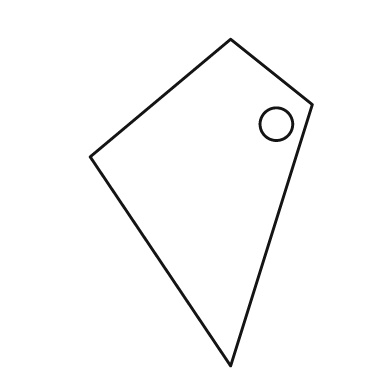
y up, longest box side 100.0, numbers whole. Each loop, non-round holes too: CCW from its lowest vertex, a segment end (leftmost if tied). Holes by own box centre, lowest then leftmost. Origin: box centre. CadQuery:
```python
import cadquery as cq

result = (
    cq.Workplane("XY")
    .moveTo(9.0, -50.0)
    .lineTo(34.0, 30.0)
    .lineTo(9.0, 50.0)
    .lineTo(-34.0, 14.0)
    .close()
    .moveTo(23.0, 24.0)
    .circle(5.0)
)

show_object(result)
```